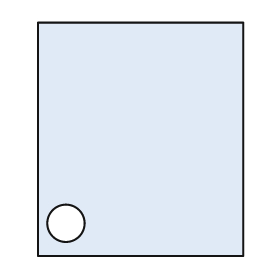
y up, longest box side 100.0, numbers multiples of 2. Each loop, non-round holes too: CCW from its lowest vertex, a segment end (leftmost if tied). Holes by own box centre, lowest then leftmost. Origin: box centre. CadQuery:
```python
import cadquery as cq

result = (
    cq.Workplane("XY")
    .moveTo(-44.0, -50.0)
    .lineTo(44.0, -50.0)
    .lineTo(44.0, 50.0)
    .lineTo(-44.0, 50.0)
    .close()
    .moveTo(-32.0, -36.0)
    .circle(8.0)
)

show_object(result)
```